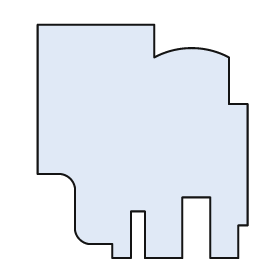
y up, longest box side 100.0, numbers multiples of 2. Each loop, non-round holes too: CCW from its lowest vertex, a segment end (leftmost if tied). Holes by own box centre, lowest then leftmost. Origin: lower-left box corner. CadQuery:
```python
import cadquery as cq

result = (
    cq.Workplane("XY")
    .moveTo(32.0, 0.0)
    .lineTo(40.0, 0.0)
    .lineTo(40.0, 20.0)
    .lineTo(46.0, 20.0)
    .lineTo(46.0, 0.0)
    .lineTo(62.0, 0.0)
    .lineTo(62.0, 26.0)
    .lineTo(74.0, 26.0)
    .lineTo(74.0, 0.0)
    .lineTo(86.0, 0.0)
    .lineTo(86.0, 14.0)
    .lineTo(90.0, 14.0)
    .lineTo(90.0, 66.0)
    .lineTo(82.0, 66.0)
    .lineTo(82.0, 86.0)
    .threePointArc((66.0, 90.0), (50.0, 86.0))
    .lineTo(50.0, 100.0)
    .lineTo(0.0, 100.0)
    .lineTo(0.0, 36.0)
    .lineTo(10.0, 36.0)
    .threePointArc((14.0, 34.0), (16.0, 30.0))
    .lineTo(16.0, 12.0)
    .threePointArc((18.0, 8.0), (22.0, 6.0))
    .lineTo(32.0, 6.0)
    .close()
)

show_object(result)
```